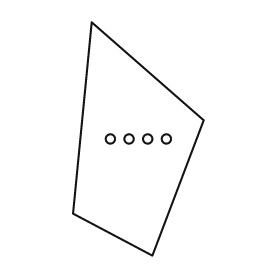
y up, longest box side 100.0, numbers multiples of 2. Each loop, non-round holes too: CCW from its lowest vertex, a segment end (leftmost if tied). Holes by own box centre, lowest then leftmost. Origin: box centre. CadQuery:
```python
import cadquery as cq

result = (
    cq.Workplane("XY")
    .moveTo(6.0, -50.0)
    .lineTo(28.0, 8.0)
    .lineTo(-20.0, 50.0)
    .lineTo(-28.0, -32.0)
    .close()
    .moveTo(-12.0, 0.0)
    .circle(2.0)
    .moveTo(-4.0, 0.0)
    .circle(2.0)
    .moveTo(4.0, 0.0)
    .circle(2.0)
    .moveTo(12.0, 0.0)
    .circle(2.0)
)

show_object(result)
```